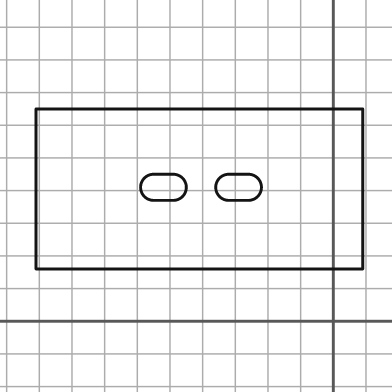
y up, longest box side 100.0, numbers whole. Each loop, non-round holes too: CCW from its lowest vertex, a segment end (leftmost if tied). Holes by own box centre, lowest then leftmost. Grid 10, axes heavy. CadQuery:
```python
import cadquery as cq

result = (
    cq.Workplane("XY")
    .moveTo(-91.0, 16.0)
    .lineTo(9.0, 16.0)
    .lineTo(9.0, 65.0)
    .lineTo(-91.0, 65.0)
    .close()
    .moveTo(-55.0, 37.0)
    .lineTo(-49.0, 37.0)
    .threePointArc((-45.0, 41.0), (-49.0, 45.0))
    .lineTo(-55.0, 45.0)
    .threePointArc((-59.0, 41.0), (-55.0, 37.0))
    .close()
    .moveTo(-32.0, 37.0)
    .lineTo(-26.0, 37.0)
    .threePointArc((-22.0, 41.0), (-26.0, 45.0))
    .lineTo(-32.0, 45.0)
    .threePointArc((-36.0, 41.0), (-32.0, 37.0))
    .close()
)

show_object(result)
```